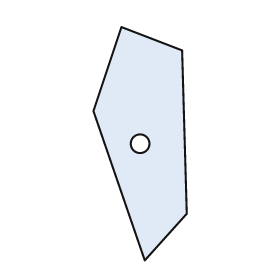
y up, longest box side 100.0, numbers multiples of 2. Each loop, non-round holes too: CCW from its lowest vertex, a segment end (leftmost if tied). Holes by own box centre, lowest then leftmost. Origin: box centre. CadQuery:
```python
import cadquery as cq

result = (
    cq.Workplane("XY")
    .moveTo(2.0, -50.0)
    .lineTo(20.0, -30.0)
    .lineTo(18.0, 40.0)
    .lineTo(-8.0, 50.0)
    .lineTo(-20.0, 14.0)
    .close()
    .moveTo(0.0, 0.0)
    .circle(4.0)
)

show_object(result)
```